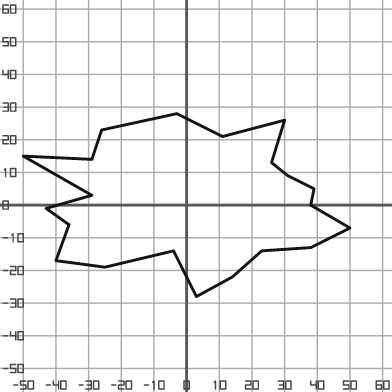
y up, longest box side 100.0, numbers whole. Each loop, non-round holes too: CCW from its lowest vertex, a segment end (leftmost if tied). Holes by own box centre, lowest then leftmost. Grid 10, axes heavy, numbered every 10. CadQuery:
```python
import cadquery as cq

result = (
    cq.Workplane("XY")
    .moveTo(3.0, -28.0)
    .lineTo(14.0, -22.0)
    .lineTo(23.0, -14.0)
    .lineTo(38.0, -13.0)
    .lineTo(50.0, -7.0)
    .lineTo(38.0, 0.0)
    .lineTo(39.0, 5.0)
    .lineTo(31.0, 9.0)
    .lineTo(26.0, 13.0)
    .lineTo(30.0, 26.0)
    .lineTo(11.0, 21.0)
    .lineTo(-3.0, 28.0)
    .lineTo(-26.0, 23.0)
    .lineTo(-29.0, 14.0)
    .lineTo(-50.0, 15.0)
    .lineTo(-29.0, 3.0)
    .lineTo(-43.0, -1.0)
    .lineTo(-36.0, -6.0)
    .lineTo(-40.0, -17.0)
    .lineTo(-25.0, -19.0)
    .lineTo(-4.0, -14.0)
    .close()
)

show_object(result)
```